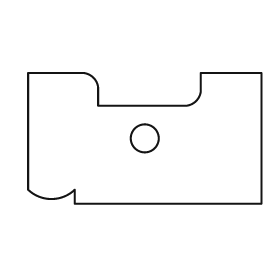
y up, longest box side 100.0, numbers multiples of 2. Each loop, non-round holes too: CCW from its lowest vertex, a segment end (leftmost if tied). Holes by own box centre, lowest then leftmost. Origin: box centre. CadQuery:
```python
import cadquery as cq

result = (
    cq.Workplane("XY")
    .moveTo(-30.0, -28.0)
    .lineTo(50.0, -28.0)
    .lineTo(50.0, 28.0)
    .lineTo(24.0, 28.0)
    .lineTo(24.0, 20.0)
    .threePointArc((22.0, 16.0), (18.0, 14.0))
    .lineTo(-20.0, 14.0)
    .lineTo(-20.0, 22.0)
    .threePointArc((-22.0, 26.0), (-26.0, 28.0))
    .lineTo(-50.0, 28.0)
    .lineTo(-50.0, -22.0)
    .threePointArc((-40.0, -26.0), (-30.0, -22.0))
    .close()
    .moveTo(0.0, 0.0)
    .circle(6.0)
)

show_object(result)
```